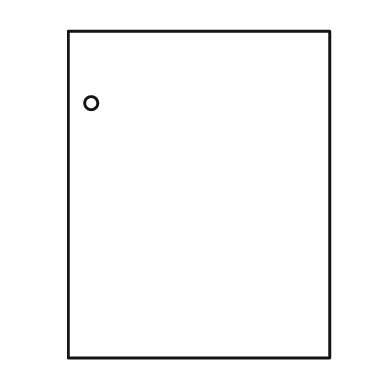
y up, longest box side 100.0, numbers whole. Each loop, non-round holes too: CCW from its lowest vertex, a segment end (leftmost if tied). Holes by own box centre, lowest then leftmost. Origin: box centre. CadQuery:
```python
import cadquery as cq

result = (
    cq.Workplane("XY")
    .moveTo(-40.0, -50.0)
    .lineTo(40.0, -50.0)
    .lineTo(40.0, 50.0)
    .lineTo(-40.0, 50.0)
    .close()
    .moveTo(-33.0, 28.0)
    .circle(2.0)
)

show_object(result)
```